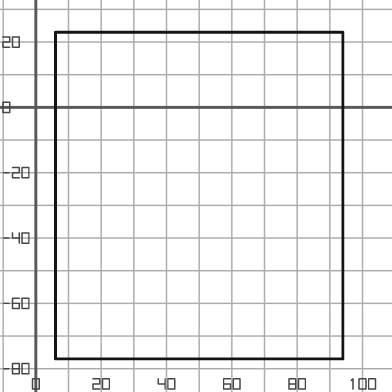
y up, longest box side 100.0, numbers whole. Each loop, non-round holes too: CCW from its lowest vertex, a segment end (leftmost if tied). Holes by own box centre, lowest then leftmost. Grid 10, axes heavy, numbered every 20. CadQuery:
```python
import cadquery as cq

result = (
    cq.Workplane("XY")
    .moveTo(6.0, -77.0)
    .lineTo(94.0, -77.0)
    .lineTo(94.0, 23.0)
    .lineTo(6.0, 23.0)
    .close()
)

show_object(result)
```